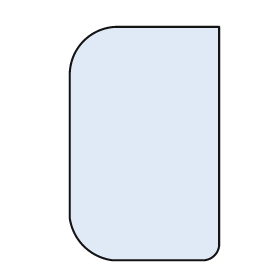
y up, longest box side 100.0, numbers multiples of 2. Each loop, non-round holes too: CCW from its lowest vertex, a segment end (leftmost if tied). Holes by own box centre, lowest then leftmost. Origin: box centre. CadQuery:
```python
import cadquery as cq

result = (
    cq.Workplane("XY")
    .moveTo(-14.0, -50.0)
    .lineTo(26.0, -50.0)
    .threePointArc((30.0, -48.0), (32.0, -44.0))
    .lineTo(32.0, 50.0)
    .lineTo(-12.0, 50.0)
    .threePointArc((-26.0, 44.0), (-32.0, 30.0))
    .lineTo(-32.0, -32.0)
    .threePointArc((-26.0, -44.0), (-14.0, -50.0))
    .close()
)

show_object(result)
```